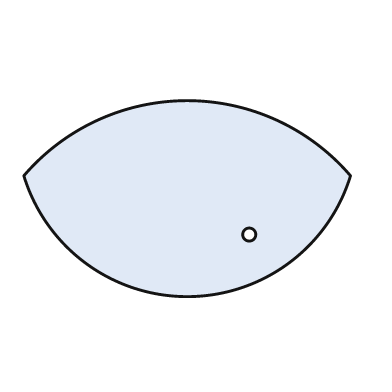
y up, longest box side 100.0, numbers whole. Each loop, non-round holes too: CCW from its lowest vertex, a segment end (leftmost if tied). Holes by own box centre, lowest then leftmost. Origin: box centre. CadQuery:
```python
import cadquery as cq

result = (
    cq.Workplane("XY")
    .moveTo(-50.0, 7.0)
    .threePointArc((0.0, -30.0), (50.0, 7.0))
    .threePointArc((0.0, 30.0), (-50.0, 7.0))
    .close()
    .moveTo(19.0, -11.0)
    .circle(2.0)
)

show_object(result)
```